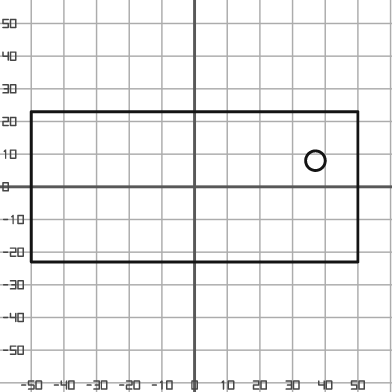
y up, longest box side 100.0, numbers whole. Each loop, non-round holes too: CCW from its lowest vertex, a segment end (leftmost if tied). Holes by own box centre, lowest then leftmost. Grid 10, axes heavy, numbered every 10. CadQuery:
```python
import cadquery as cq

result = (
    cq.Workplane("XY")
    .moveTo(-50.0, -23.0)
    .lineTo(50.0, -23.0)
    .lineTo(50.0, 23.0)
    .lineTo(-50.0, 23.0)
    .close()
    .moveTo(37.0, 8.0)
    .circle(3.0)
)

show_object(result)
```